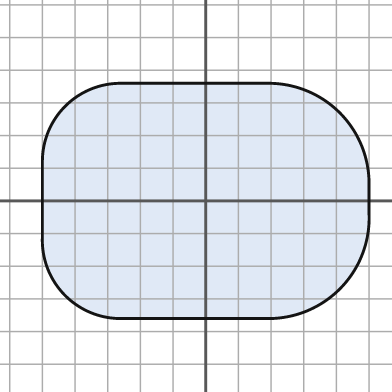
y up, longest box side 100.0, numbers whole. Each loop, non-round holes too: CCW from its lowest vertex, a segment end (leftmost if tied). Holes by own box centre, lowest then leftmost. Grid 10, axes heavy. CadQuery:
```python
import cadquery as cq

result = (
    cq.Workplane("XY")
    .moveTo(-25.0, -36.0)
    .lineTo(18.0, -36.0)
    .threePointArc((41.0, -27.0), (50.0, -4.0))
    .lineTo(50.0, 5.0)
    .threePointArc((41.0, 27.0), (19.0, 36.0))
    .lineTo(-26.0, 36.0)
    .threePointArc((-43.0, 29.0), (-50.0, 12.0))
    .lineTo(-50.0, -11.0)
    .threePointArc((-43.0, -29.0), (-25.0, -36.0))
    .close()
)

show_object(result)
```